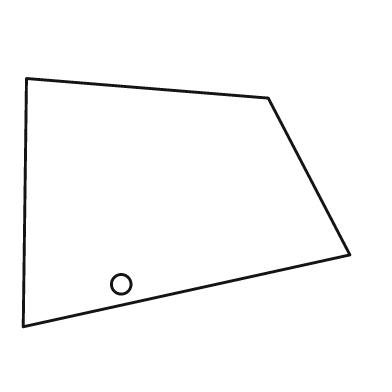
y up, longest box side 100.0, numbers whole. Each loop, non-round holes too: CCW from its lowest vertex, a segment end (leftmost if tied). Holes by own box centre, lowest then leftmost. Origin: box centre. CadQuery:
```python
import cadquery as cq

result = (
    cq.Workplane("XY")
    .moveTo(-50.0, -38.0)
    .lineTo(50.0, -16.0)
    .lineTo(25.0, 32.0)
    .lineTo(-49.0, 38.0)
    .close()
    .moveTo(-20.0, -25.0)
    .circle(3.0)
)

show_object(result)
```